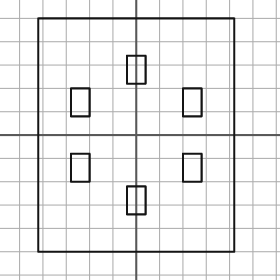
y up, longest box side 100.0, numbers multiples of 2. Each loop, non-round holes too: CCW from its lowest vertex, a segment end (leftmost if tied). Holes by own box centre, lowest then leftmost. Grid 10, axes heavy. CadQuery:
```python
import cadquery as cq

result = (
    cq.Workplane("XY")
    .moveTo(-42.0, -50.0)
    .lineTo(42.0, -50.0)
    .lineTo(42.0, 50.0)
    .lineTo(-42.0, 50.0)
    .close()
    .moveTo(-4.0, -34.0)
    .lineTo(4.0, -34.0)
    .lineTo(4.0, -22.0)
    .lineTo(-4.0, -22.0)
    .close()
    .moveTo(-28.0, -20.0)
    .lineTo(-20.0, -20.0)
    .lineTo(-20.0, -8.0)
    .lineTo(-28.0, -8.0)
    .close()
    .moveTo(20.0, -20.0)
    .lineTo(28.0, -20.0)
    .lineTo(28.0, -8.0)
    .lineTo(20.0, -8.0)
    .close()
    .moveTo(-28.0, 8.0)
    .lineTo(-20.0, 8.0)
    .lineTo(-20.0, 20.0)
    .lineTo(-28.0, 20.0)
    .close()
    .moveTo(20.0, 8.0)
    .lineTo(28.0, 8.0)
    .lineTo(28.0, 20.0)
    .lineTo(20.0, 20.0)
    .close()
    .moveTo(-4.0, 22.0)
    .lineTo(4.0, 22.0)
    .lineTo(4.0, 34.0)
    .lineTo(-4.0, 34.0)
    .close()
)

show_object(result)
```